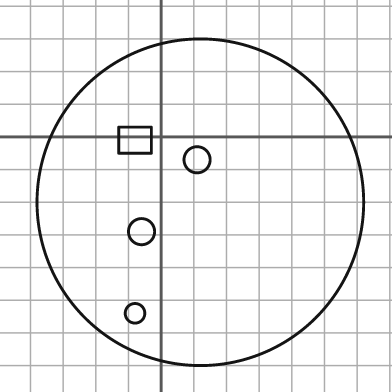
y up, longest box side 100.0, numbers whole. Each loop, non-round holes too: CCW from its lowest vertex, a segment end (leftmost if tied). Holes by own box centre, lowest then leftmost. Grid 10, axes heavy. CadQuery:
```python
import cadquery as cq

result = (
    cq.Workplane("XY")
    .moveTo(12.0, -20.0)
    .circle(50.0)
    .moveTo(-8.0, -54.0)
    .circle(3.0)
    .moveTo(-6.0, -29.0)
    .circle(4.0)
    .moveTo(11.0, -7.0)
    .circle(4.0)
    .moveTo(-13.0, -5.0)
    .lineTo(-3.0, -5.0)
    .lineTo(-3.0, 3.0)
    .lineTo(-13.0, 3.0)
    .close()
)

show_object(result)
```